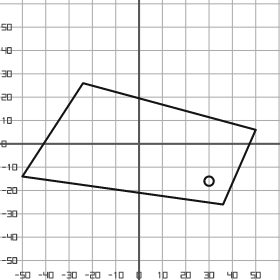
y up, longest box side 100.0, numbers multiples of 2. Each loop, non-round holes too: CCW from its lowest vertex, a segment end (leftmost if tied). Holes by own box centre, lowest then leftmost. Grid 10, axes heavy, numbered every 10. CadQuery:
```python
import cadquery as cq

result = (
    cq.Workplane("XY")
    .moveTo(36.0, -26.0)
    .lineTo(50.0, 6.0)
    .lineTo(-24.0, 26.0)
    .lineTo(-50.0, -14.0)
    .close()
    .moveTo(30.0, -16.0)
    .circle(2.0)
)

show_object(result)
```